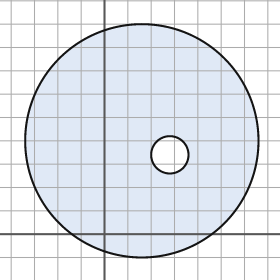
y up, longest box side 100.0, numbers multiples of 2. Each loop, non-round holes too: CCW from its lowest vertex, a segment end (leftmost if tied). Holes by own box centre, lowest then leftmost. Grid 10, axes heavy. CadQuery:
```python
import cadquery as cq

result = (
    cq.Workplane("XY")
    .moveTo(16.0, 40.0)
    .circle(50.0)
    .moveTo(28.0, 34.0)
    .circle(8.0)
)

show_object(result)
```